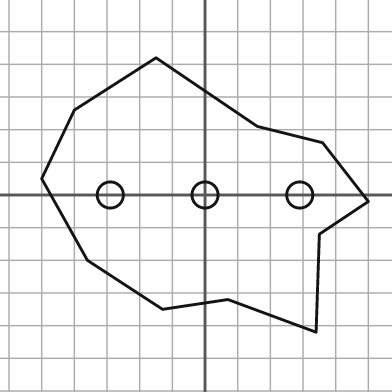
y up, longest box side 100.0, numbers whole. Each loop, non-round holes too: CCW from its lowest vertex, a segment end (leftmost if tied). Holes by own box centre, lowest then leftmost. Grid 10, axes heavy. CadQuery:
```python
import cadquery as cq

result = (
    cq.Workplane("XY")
    .moveTo(34.0, -42.0)
    .lineTo(35.0, -12.0)
    .lineTo(50.0, -2.0)
    .lineTo(36.0, 16.0)
    .lineTo(16.0, 21.0)
    .lineTo(-15.0, 42.0)
    .lineTo(-40.0, 26.0)
    .lineTo(-50.0, 5.0)
    .lineTo(-36.0, -20.0)
    .lineTo(-13.0, -35.0)
    .lineTo(7.0, -32.0)
    .close()
    .moveTo(-29.0, 0.0)
    .circle(4.0)
    .moveTo(0.0, 0.0)
    .circle(4.0)
    .moveTo(29.0, 0.0)
    .circle(4.0)
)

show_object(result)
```